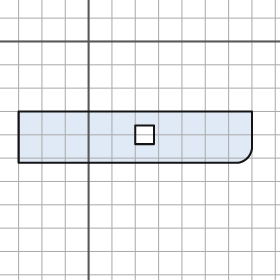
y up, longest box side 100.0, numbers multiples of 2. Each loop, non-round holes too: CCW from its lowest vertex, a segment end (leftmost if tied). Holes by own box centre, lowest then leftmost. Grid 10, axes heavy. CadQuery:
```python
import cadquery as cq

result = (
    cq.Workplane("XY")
    .moveTo(-30.0, -52.0)
    .lineTo(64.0, -52.0)
    .threePointArc((68.0, -50.0), (70.0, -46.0))
    .lineTo(70.0, -30.0)
    .lineTo(-30.0, -30.0)
    .close()
    .moveTo(20.0, -44.0)
    .lineTo(28.0, -44.0)
    .lineTo(28.0, -36.0)
    .lineTo(20.0, -36.0)
    .close()
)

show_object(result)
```